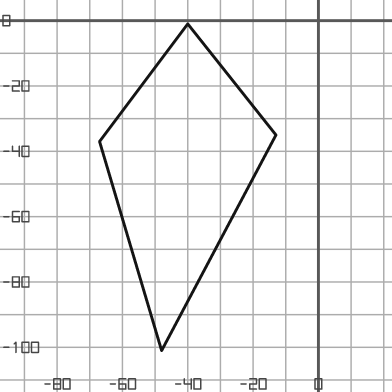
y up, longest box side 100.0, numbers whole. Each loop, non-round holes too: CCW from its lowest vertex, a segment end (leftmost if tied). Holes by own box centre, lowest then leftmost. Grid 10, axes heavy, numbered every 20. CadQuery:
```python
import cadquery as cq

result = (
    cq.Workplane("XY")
    .moveTo(-48.0, -101.0)
    .lineTo(-13.0, -35.0)
    .lineTo(-40.0, -1.0)
    .lineTo(-67.0, -37.0)
    .close()
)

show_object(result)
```